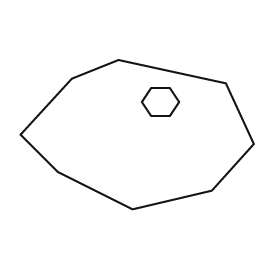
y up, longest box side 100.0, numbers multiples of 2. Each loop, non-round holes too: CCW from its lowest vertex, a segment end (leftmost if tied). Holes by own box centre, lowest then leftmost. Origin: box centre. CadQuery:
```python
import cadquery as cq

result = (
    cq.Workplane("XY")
    .moveTo(-2.0, -32.0)
    .lineTo(32.0, -24.0)
    .lineTo(50.0, -4.0)
    .lineTo(38.0, 22.0)
    .lineTo(-8.0, 32.0)
    .lineTo(-28.0, 24.0)
    .lineTo(-50.0, 0.0)
    .lineTo(-34.0, -16.0)
    .close()
    .moveTo(6.0, 8.0)
    .lineTo(14.0, 8.0)
    .lineTo(18.0, 14.0)
    .lineTo(14.0, 20.0)
    .lineTo(6.0, 20.0)
    .lineTo(2.0, 14.0)
    .close()
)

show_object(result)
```